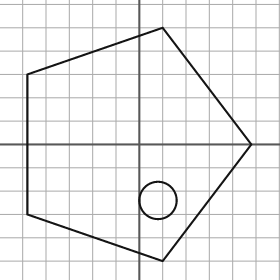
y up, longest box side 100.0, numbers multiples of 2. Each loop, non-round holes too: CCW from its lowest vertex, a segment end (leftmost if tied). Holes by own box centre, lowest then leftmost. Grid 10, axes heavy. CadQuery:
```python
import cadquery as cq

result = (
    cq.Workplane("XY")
    .moveTo(10.0, -50.0)
    .lineTo(48.0, 0.0)
    .lineTo(10.0, 50.0)
    .lineTo(-48.0, 30.0)
    .lineTo(-48.0, -30.0)
    .close()
    .moveTo(8.0, -24.0)
    .circle(8.0)
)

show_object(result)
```